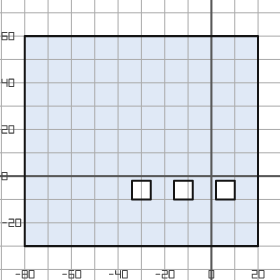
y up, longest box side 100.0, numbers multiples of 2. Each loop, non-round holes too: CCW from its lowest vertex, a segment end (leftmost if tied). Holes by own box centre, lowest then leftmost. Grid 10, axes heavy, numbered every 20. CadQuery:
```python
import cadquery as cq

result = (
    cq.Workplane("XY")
    .moveTo(-80.0, -30.0)
    .lineTo(20.0, -30.0)
    .lineTo(20.0, 60.0)
    .lineTo(-80.0, 60.0)
    .close()
    .moveTo(-34.0, -10.0)
    .lineTo(-26.0, -10.0)
    .lineTo(-26.0, -2.0)
    .lineTo(-34.0, -2.0)
    .close()
    .moveTo(-16.0, -10.0)
    .lineTo(-8.0, -10.0)
    .lineTo(-8.0, -2.0)
    .lineTo(-16.0, -2.0)
    .close()
    .moveTo(2.0, -10.0)
    .lineTo(10.0, -10.0)
    .lineTo(10.0, -2.0)
    .lineTo(2.0, -2.0)
    .close()
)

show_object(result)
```